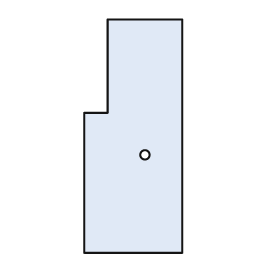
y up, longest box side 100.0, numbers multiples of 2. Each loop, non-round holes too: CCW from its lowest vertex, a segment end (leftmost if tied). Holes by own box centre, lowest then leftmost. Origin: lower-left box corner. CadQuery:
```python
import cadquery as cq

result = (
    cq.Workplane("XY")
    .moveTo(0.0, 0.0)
    .lineTo(42.0, 0.0)
    .lineTo(42.0, 100.0)
    .lineTo(10.0, 100.0)
    .lineTo(10.0, 60.0)
    .lineTo(0.0, 60.0)
    .close()
    .moveTo(26.0, 42.0)
    .circle(2.0)
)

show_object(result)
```